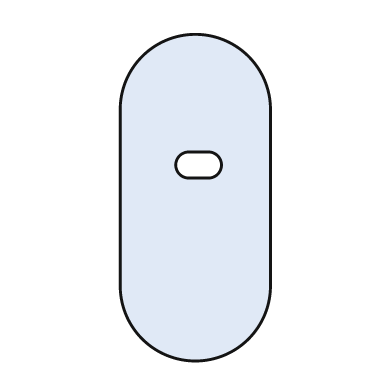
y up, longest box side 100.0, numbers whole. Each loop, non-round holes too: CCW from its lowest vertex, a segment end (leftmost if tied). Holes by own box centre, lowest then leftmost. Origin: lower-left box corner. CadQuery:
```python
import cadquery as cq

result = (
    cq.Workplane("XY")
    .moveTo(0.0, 23.0)
    .threePointArc((23.0, 0.0), (46.0, 23.0))
    .lineTo(46.0, 77.0)
    .threePointArc((23.0, 100.0), (0.0, 77.0))
    .close()
    .moveTo(21.0, 56.0)
    .lineTo(27.0, 56.0)
    .threePointArc((31.0, 60.0), (27.0, 64.0))
    .lineTo(21.0, 64.0)
    .threePointArc((17.0, 60.0), (21.0, 56.0))
    .close()
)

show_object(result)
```